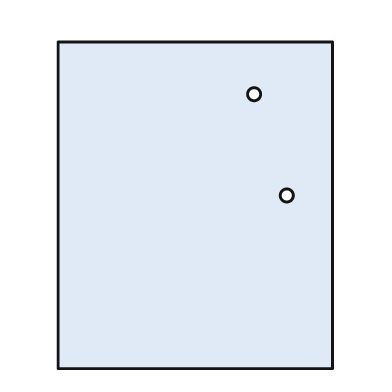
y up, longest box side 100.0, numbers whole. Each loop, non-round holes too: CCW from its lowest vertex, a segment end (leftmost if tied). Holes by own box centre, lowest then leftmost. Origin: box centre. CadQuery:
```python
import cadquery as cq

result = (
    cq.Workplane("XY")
    .moveTo(-42.0, -50.0)
    .lineTo(42.0, -50.0)
    .lineTo(42.0, 50.0)
    .lineTo(-42.0, 50.0)
    .close()
    .moveTo(28.0, 3.0)
    .circle(2.0)
    .moveTo(18.0, 34.0)
    .circle(2.0)
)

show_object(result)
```